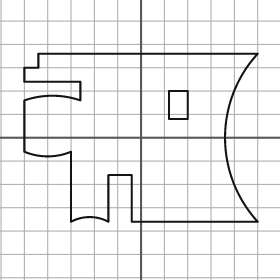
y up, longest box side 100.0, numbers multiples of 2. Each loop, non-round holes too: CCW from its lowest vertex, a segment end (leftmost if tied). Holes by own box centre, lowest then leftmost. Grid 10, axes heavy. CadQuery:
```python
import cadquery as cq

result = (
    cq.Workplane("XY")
    .moveTo(-30.0, -36.0)
    .threePointArc((-22.0, -34.0), (-14.0, -36.0))
    .lineTo(-14.0, -16.0)
    .lineTo(-4.0, -16.0)
    .lineTo(-4.0, -36.0)
    .lineTo(50.0, -36.0)
    .threePointArc((36.0, 0.0), (50.0, 36.0))
    .lineTo(-44.0, 36.0)
    .lineTo(-44.0, 30.0)
    .lineTo(-50.0, 30.0)
    .lineTo(-50.0, 24.0)
    .lineTo(-26.0, 24.0)
    .lineTo(-26.0, 16.0)
    .threePointArc((-38.0, 18.0), (-50.0, 16.0))
    .lineTo(-50.0, -6.0)
    .threePointArc((-40.0, -8.0), (-30.0, -6.0))
    .close()
    .moveTo(12.0, 8.0)
    .lineTo(20.0, 8.0)
    .lineTo(20.0, 20.0)
    .lineTo(12.0, 20.0)
    .close()
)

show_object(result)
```